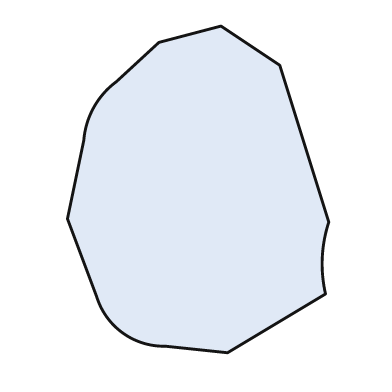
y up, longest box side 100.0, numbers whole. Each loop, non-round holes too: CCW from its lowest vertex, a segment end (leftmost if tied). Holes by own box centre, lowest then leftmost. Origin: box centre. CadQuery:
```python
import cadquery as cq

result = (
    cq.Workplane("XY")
    .moveTo(9.0, -50.0)
    .lineTo(39.0, -32.0)
    .threePointArc((38.0, -21.0), (40.0, -10.0))
    .lineTo(25.0, 38.0)
    .lineTo(7.0, 50.0)
    .lineTo(-12.0, 45.0)
    .lineTo(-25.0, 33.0)
    .threePointArc((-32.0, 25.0), (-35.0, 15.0))
    .lineTo(-40.0, -9.0)
    .lineTo(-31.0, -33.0)
    .threePointArc((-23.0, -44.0), (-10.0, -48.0))
    .close()
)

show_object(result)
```